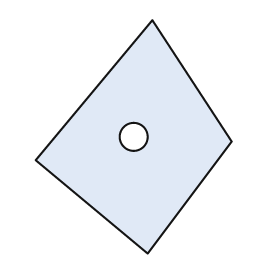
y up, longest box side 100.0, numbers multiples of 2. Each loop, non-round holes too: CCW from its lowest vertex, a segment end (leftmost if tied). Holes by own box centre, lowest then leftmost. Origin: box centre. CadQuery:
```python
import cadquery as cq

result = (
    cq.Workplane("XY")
    .moveTo(6.0, -50.0)
    .lineTo(42.0, -2.0)
    .lineTo(8.0, 50.0)
    .lineTo(-42.0, -10.0)
    .close()
    .moveTo(0.0, 0.0)
    .circle(6.0)
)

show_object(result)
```